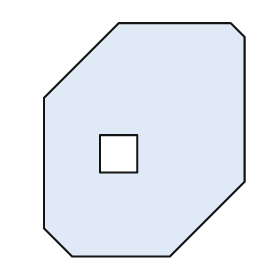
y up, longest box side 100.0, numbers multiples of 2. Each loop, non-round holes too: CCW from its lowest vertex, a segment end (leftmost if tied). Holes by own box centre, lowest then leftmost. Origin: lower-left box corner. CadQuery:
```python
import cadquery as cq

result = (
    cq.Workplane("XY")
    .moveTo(12.0, 0.0)
    .lineTo(54.0, 0.0)
    .lineTo(86.0, 32.0)
    .lineTo(86.0, 94.0)
    .lineTo(80.0, 100.0)
    .lineTo(32.0, 100.0)
    .lineTo(0.0, 68.0)
    .lineTo(0.0, 12.0)
    .close()
    .moveTo(24.0, 36.0)
    .lineTo(40.0, 36.0)
    .lineTo(40.0, 52.0)
    .lineTo(24.0, 52.0)
    .close()
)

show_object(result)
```